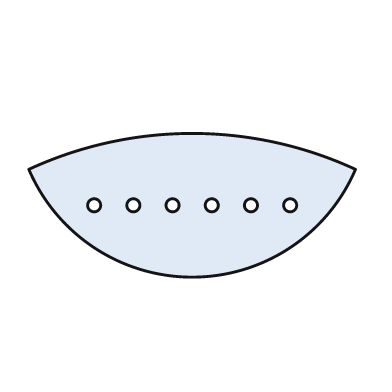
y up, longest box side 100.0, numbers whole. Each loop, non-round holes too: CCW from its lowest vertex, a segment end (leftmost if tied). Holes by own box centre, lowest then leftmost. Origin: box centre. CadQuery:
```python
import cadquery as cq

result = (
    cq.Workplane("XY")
    .moveTo(-50.0, 11.0)
    .threePointArc((0.0, -22.0), (50.0, 11.0))
    .threePointArc((0.0, 22.0), (-50.0, 11.0))
    .close()
    .moveTo(-30.0, 0.0)
    .circle(2.0)
    .moveTo(-18.0, 0.0)
    .circle(2.0)
    .moveTo(-6.0, 0.0)
    .circle(2.0)
    .moveTo(6.0, 0.0)
    .circle(2.0)
    .moveTo(18.0, 0.0)
    .circle(2.0)
    .moveTo(30.0, 0.0)
    .circle(2.0)
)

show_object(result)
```